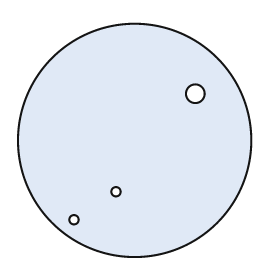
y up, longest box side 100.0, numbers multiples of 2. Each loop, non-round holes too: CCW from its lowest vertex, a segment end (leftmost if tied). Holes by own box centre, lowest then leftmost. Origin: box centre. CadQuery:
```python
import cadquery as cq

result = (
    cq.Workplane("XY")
    .moveTo(0.0, 0.0)
    .circle(50.0)
    .moveTo(-26.0, -34.0)
    .circle(2.0)
    .moveTo(-8.0, -22.0)
    .circle(2.0)
    .moveTo(26.0, 20.0)
    .circle(4.0)
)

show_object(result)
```